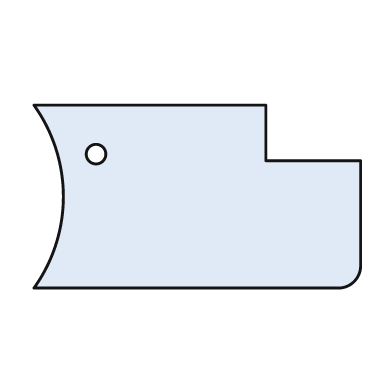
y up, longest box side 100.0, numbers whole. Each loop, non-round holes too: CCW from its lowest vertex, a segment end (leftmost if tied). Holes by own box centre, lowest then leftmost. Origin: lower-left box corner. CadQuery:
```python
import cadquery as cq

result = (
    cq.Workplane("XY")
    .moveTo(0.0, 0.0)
    .lineTo(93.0, 0.0)
    .threePointArc((98.0, 2.0), (100.0, 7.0))
    .lineTo(100.0, 39.0)
    .lineTo(71.0, 39.0)
    .lineTo(71.0, 56.0)
    .lineTo(0.0, 56.0)
    .threePointArc((9.0, 28.0), (0.0, 0.0))
    .close()
    .moveTo(19.0, 41.0)
    .circle(3.0)
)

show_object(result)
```